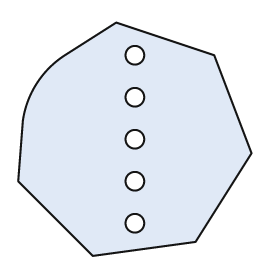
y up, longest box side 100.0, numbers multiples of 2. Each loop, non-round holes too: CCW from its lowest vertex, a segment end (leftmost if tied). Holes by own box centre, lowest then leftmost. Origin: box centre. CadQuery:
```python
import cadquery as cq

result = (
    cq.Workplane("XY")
    .moveTo(-18.0, -50.0)
    .lineTo(26.0, -44.0)
    .lineTo(50.0, -6.0)
    .lineTo(34.0, 36.0)
    .lineTo(-8.0, 50.0)
    .lineTo(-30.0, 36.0)
    .threePointArc((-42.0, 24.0), (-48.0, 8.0))
    .lineTo(-50.0, -18.0)
    .close()
    .moveTo(0.0, -36.0)
    .circle(4.0)
    .moveTo(0.0, -18.0)
    .circle(4.0)
    .moveTo(0.0, 0.0)
    .circle(4.0)
    .moveTo(0.0, 18.0)
    .circle(4.0)
    .moveTo(0.0, 36.0)
    .circle(4.0)
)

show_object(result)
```